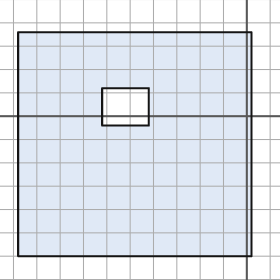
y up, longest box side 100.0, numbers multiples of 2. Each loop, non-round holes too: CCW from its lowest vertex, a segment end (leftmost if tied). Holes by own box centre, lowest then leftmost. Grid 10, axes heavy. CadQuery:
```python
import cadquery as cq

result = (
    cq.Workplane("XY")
    .moveTo(-98.0, -60.0)
    .lineTo(2.0, -60.0)
    .lineTo(2.0, 36.0)
    .lineTo(-98.0, 36.0)
    .close()
    .moveTo(-62.0, -4.0)
    .lineTo(-42.0, -4.0)
    .lineTo(-42.0, 12.0)
    .lineTo(-62.0, 12.0)
    .close()
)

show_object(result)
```